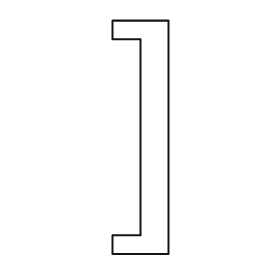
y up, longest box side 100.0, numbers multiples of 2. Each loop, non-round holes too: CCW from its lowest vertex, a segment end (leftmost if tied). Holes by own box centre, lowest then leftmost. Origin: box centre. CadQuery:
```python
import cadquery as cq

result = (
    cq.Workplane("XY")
    .moveTo(-12.0, -50.0)
    .lineTo(12.0, -50.0)
    .lineTo(12.0, 50.0)
    .lineTo(-12.0, 50.0)
    .lineTo(-12.0, 42.0)
    .lineTo(0.0, 42.0)
    .lineTo(0.0, -42.0)
    .lineTo(-12.0, -42.0)
    .close()
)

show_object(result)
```